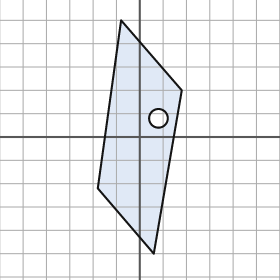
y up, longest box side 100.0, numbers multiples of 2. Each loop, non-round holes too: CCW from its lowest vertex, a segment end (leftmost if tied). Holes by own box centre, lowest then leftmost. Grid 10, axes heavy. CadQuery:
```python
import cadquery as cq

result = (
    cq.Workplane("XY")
    .moveTo(6.0, -50.0)
    .lineTo(18.0, 20.0)
    .lineTo(-8.0, 50.0)
    .lineTo(-18.0, -22.0)
    .close()
    .moveTo(8.0, 8.0)
    .circle(4.0)
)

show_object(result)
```